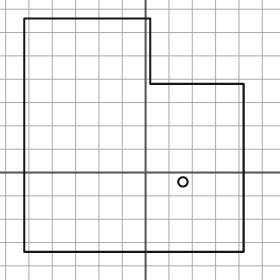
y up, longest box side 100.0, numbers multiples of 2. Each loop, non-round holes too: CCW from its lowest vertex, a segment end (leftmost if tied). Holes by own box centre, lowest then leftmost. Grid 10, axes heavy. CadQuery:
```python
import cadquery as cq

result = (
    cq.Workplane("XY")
    .moveTo(-52.0, -34.0)
    .lineTo(42.0, -34.0)
    .lineTo(42.0, 38.0)
    .lineTo(2.0, 38.0)
    .lineTo(2.0, 66.0)
    .lineTo(-52.0, 66.0)
    .close()
    .moveTo(16.0, -4.0)
    .circle(2.0)
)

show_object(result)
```